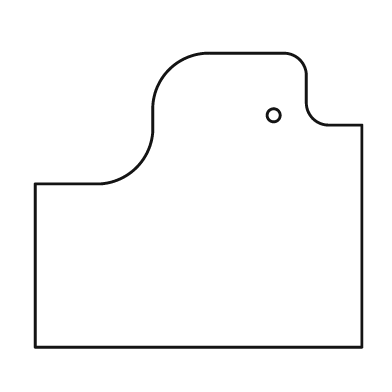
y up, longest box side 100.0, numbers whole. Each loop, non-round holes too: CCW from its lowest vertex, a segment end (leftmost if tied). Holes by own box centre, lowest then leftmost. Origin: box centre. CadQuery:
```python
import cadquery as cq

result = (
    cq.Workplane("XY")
    .moveTo(-50.0, -45.0)
    .lineTo(50.0, -45.0)
    .lineTo(50.0, 23.0)
    .lineTo(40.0, 23.0)
    .threePointArc((35.0, 25.0), (33.0, 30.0))
    .lineTo(33.0, 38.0)
    .threePointArc((31.0, 43.0), (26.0, 45.0))
    .lineTo(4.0, 45.0)
    .threePointArc((-9.0, 40.0), (-14.0, 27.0))
    .lineTo(-14.0, 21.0)
    .threePointArc((-19.0, 10.0), (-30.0, 5.0))
    .lineTo(-50.0, 5.0)
    .close()
    .moveTo(23.0, 26.0)
    .circle(2.0)
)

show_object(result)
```